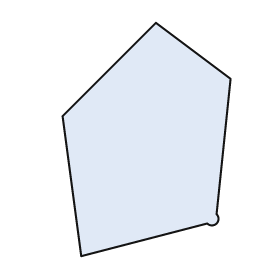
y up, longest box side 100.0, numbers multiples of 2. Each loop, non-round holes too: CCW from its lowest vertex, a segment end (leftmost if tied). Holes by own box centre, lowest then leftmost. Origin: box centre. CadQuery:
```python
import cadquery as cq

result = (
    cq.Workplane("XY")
    .moveTo(-28.0, -50.0)
    .lineTo(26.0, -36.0)
    .threePointArc((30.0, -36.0), (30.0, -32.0))
    .lineTo(36.0, 26.0)
    .lineTo(4.0, 50.0)
    .lineTo(-36.0, 10.0)
    .close()
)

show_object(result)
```